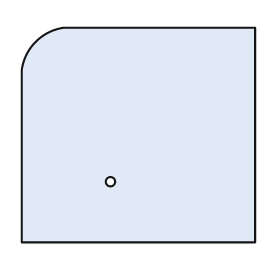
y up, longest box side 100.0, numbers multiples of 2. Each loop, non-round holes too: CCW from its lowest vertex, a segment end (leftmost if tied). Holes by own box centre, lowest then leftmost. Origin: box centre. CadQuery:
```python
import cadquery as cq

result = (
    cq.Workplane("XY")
    .moveTo(-50.0, -46.0)
    .lineTo(50.0, -46.0)
    .lineTo(50.0, 46.0)
    .lineTo(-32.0, 46.0)
    .threePointArc((-44.0, 40.0), (-50.0, 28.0))
    .close()
    .moveTo(-12.0, -20.0)
    .circle(2.0)
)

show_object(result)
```